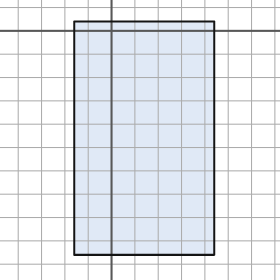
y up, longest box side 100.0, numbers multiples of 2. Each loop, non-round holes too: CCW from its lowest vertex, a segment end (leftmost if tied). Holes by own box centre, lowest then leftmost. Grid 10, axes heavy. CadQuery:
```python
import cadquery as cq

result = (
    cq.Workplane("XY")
    .moveTo(-16.0, -96.0)
    .lineTo(44.0, -96.0)
    .lineTo(44.0, 4.0)
    .lineTo(-16.0, 4.0)
    .close()
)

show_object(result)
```